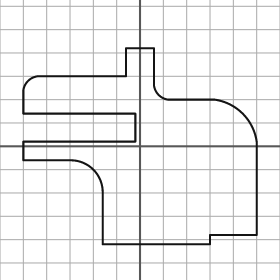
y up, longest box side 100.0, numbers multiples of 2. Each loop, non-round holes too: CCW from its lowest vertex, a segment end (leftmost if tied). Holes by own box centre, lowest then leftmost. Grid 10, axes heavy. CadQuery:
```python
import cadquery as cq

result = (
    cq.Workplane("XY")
    .moveTo(-16.0, -42.0)
    .lineTo(30.0, -42.0)
    .lineTo(30.0, -38.0)
    .lineTo(50.0, -38.0)
    .lineTo(50.0, 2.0)
    .threePointArc((44.0, 14.0), (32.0, 20.0))
    .lineTo(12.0, 20.0)
    .threePointArc((8.0, 22.0), (6.0, 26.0))
    .lineTo(6.0, 42.0)
    .lineTo(-6.0, 42.0)
    .lineTo(-6.0, 30.0)
    .lineTo(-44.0, 30.0)
    .threePointArc((-48.0, 28.0), (-50.0, 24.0))
    .lineTo(-50.0, 14.0)
    .lineTo(-2.0, 14.0)
    .lineTo(-2.0, 2.0)
    .lineTo(-50.0, 2.0)
    .lineTo(-50.0, -6.0)
    .lineTo(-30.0, -6.0)
    .threePointArc((-20.0, -10.0), (-16.0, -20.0))
    .close()
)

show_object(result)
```